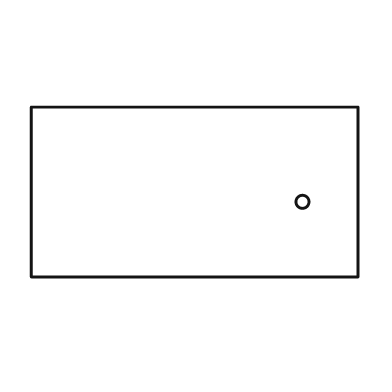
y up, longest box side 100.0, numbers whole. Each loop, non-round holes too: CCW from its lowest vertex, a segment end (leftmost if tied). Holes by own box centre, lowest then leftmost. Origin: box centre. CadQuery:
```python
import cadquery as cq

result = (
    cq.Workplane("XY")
    .moveTo(-50.0, -26.0)
    .lineTo(50.0, -26.0)
    .lineTo(50.0, 26.0)
    .lineTo(-50.0, 26.0)
    .close()
    .moveTo(33.0, -3.0)
    .circle(2.0)
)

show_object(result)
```